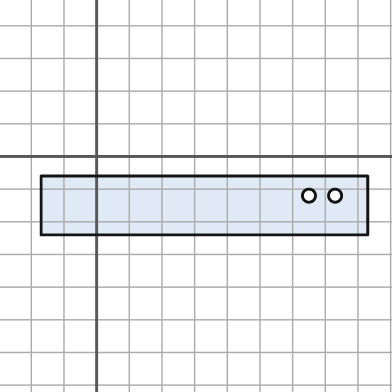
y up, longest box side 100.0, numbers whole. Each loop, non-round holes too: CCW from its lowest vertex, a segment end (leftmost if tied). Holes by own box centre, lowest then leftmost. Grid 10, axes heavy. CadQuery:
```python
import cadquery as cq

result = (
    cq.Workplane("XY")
    .moveTo(-17.0, -24.0)
    .lineTo(83.0, -24.0)
    .lineTo(83.0, -6.0)
    .lineTo(-17.0, -6.0)
    .close()
    .moveTo(65.0, -12.0)
    .circle(2.0)
    .moveTo(73.0, -12.0)
    .circle(2.0)
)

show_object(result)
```